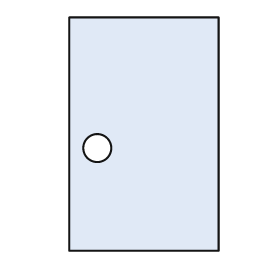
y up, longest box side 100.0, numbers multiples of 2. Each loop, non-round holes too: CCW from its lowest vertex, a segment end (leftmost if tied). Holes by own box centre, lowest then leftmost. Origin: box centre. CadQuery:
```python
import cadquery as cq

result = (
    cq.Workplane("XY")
    .moveTo(-32.0, -50.0)
    .lineTo(32.0, -50.0)
    .lineTo(32.0, 50.0)
    .lineTo(-32.0, 50.0)
    .close()
    .moveTo(-20.0, -6.0)
    .circle(6.0)
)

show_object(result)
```